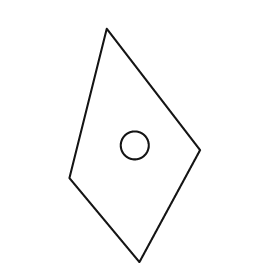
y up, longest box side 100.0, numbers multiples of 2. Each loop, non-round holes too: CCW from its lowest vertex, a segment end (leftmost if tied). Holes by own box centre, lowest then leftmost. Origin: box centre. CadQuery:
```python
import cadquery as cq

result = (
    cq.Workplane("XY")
    .moveTo(2.0, -50.0)
    .lineTo(28.0, -2.0)
    .lineTo(-12.0, 50.0)
    .lineTo(-28.0, -14.0)
    .close()
    .moveTo(0.0, 0.0)
    .circle(6.0)
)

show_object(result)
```